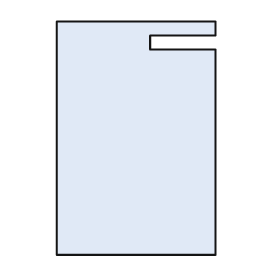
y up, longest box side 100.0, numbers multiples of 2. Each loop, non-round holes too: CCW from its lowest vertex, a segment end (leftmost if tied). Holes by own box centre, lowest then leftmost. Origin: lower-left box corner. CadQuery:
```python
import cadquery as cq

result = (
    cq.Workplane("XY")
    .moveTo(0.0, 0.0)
    .lineTo(68.0, 0.0)
    .lineTo(68.0, 88.0)
    .lineTo(40.0, 88.0)
    .lineTo(40.0, 94.0)
    .lineTo(68.0, 94.0)
    .lineTo(68.0, 100.0)
    .lineTo(0.0, 100.0)
    .close()
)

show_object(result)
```